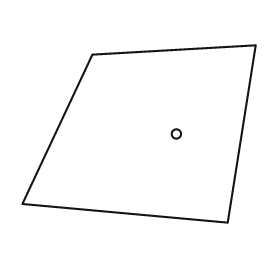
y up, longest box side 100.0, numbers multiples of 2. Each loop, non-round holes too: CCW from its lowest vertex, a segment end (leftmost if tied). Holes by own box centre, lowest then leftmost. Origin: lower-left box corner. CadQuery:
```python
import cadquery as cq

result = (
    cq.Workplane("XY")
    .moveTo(88.0, 0.0)
    .lineTo(100.0, 76.0)
    .lineTo(30.0, 72.0)
    .lineTo(0.0, 8.0)
    .close()
    .moveTo(66.0, 38.0)
    .circle(2.0)
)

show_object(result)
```